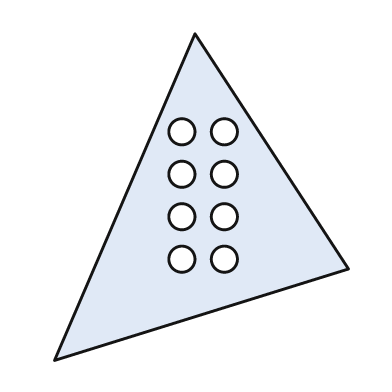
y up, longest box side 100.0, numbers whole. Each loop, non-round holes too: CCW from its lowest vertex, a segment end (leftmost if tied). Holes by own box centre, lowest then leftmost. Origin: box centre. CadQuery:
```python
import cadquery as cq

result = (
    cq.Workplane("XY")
    .moveTo(-45.0, -50.0)
    .lineTo(45.0, -22.0)
    .lineTo(-2.0, 50.0)
    .close()
    .moveTo(-6.0, -19.0)
    .circle(4.0)
    .moveTo(7.0, -19.0)
    .circle(4.0)
    .moveTo(-6.0, -6.0)
    .circle(4.0)
    .moveTo(7.0, -6.0)
    .circle(4.0)
    .moveTo(-6.0, 7.0)
    .circle(4.0)
    .moveTo(7.0, 7.0)
    .circle(4.0)
    .moveTo(-6.0, 20.0)
    .circle(4.0)
    .moveTo(7.0, 20.0)
    .circle(4.0)
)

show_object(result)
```